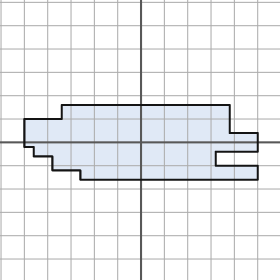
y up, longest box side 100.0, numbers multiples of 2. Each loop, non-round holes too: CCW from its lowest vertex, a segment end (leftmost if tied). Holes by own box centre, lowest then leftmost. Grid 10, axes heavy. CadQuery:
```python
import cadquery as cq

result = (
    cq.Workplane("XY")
    .moveTo(-26.0, -16.0)
    .lineTo(50.0, -16.0)
    .lineTo(50.0, -10.0)
    .lineTo(32.0, -10.0)
    .lineTo(32.0, -4.0)
    .lineTo(50.0, -4.0)
    .lineTo(50.0, 4.0)
    .lineTo(38.0, 4.0)
    .lineTo(38.0, 16.0)
    .lineTo(-34.0, 16.0)
    .lineTo(-34.0, 10.0)
    .lineTo(-50.0, 10.0)
    .lineTo(-50.0, -2.0)
    .lineTo(-46.0, -2.0)
    .lineTo(-46.0, -6.0)
    .lineTo(-38.0, -6.0)
    .lineTo(-38.0, -12.0)
    .lineTo(-26.0, -12.0)
    .close()
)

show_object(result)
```